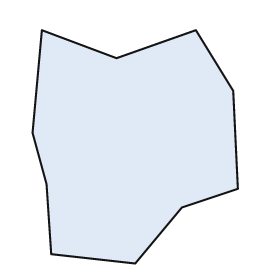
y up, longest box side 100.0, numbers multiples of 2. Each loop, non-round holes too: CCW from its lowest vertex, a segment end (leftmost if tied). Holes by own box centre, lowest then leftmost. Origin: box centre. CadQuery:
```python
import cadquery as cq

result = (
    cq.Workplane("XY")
    .moveTo(0.0, -50.0)
    .lineTo(20.0, -26.0)
    .lineTo(44.0, -18.0)
    .lineTo(42.0, 24.0)
    .lineTo(26.0, 50.0)
    .lineTo(-8.0, 38.0)
    .lineTo(-40.0, 50.0)
    .lineTo(-44.0, 6.0)
    .lineTo(-38.0, -16.0)
    .lineTo(-36.0, -46.0)
    .close()
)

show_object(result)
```